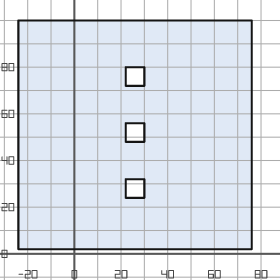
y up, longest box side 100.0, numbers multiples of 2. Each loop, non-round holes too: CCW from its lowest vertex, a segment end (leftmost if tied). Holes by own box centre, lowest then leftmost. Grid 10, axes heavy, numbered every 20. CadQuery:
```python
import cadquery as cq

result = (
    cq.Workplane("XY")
    .moveTo(-24.0, 2.0)
    .lineTo(76.0, 2.0)
    .lineTo(76.0, 100.0)
    .lineTo(-24.0, 100.0)
    .close()
    .moveTo(22.0, 24.0)
    .lineTo(30.0, 24.0)
    .lineTo(30.0, 32.0)
    .lineTo(22.0, 32.0)
    .close()
    .moveTo(22.0, 48.0)
    .lineTo(30.0, 48.0)
    .lineTo(30.0, 56.0)
    .lineTo(22.0, 56.0)
    .close()
    .moveTo(22.0, 72.0)
    .lineTo(30.0, 72.0)
    .lineTo(30.0, 80.0)
    .lineTo(22.0, 80.0)
    .close()
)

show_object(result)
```